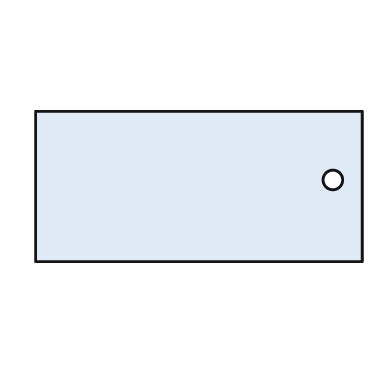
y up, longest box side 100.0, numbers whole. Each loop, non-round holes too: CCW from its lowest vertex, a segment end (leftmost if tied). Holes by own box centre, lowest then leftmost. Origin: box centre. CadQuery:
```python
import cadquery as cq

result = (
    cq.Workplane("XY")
    .moveTo(-50.0, -23.0)
    .lineTo(50.0, -23.0)
    .lineTo(50.0, 23.0)
    .lineTo(-50.0, 23.0)
    .close()
    .moveTo(41.0, 2.0)
    .circle(3.0)
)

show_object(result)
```